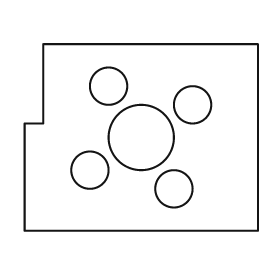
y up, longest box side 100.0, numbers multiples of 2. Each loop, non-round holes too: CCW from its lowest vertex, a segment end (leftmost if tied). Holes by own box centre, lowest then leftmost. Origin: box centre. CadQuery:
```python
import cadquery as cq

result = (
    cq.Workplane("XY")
    .moveTo(-50.0, -40.0)
    .lineTo(50.0, -40.0)
    .lineTo(50.0, 40.0)
    .lineTo(-42.0, 40.0)
    .lineTo(-42.0, 6.0)
    .lineTo(-50.0, 6.0)
    .close()
    .moveTo(14.0, -22.0)
    .circle(8.0)
    .moveTo(-22.0, -14.0)
    .circle(8.0)
    .moveTo(0.0, 0.0)
    .circle(14.0)
    .moveTo(22.0, 14.0)
    .circle(8.0)
    .moveTo(-14.0, 22.0)
    .circle(8.0)
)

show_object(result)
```